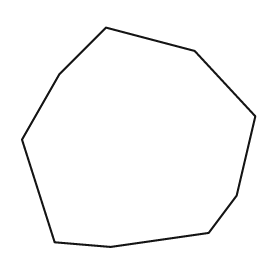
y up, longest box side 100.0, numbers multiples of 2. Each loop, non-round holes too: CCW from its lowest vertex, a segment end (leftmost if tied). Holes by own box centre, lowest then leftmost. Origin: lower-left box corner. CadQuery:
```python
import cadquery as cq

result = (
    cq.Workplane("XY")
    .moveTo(38.0, 0.0)
    .lineTo(80.0, 6.0)
    .lineTo(92.0, 22.0)
    .lineTo(100.0, 56.0)
    .lineTo(74.0, 84.0)
    .lineTo(36.0, 94.0)
    .lineTo(16.0, 74.0)
    .lineTo(0.0, 46.0)
    .lineTo(14.0, 2.0)
    .close()
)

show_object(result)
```